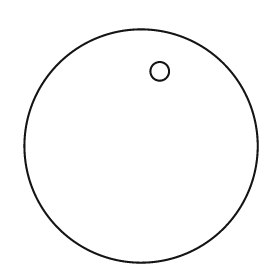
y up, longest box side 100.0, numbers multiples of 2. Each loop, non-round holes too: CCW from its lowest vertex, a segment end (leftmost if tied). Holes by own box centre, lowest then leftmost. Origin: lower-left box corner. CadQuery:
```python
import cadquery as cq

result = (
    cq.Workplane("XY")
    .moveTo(50.0, 50.0)
    .circle(50.0)
    .moveTo(58.0, 82.0)
    .circle(4.0)
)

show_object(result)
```